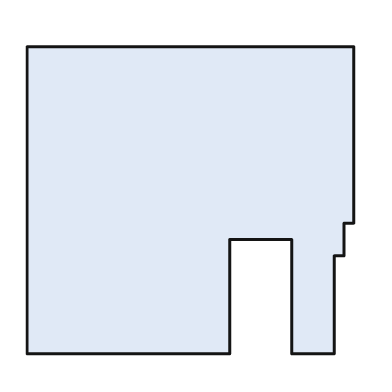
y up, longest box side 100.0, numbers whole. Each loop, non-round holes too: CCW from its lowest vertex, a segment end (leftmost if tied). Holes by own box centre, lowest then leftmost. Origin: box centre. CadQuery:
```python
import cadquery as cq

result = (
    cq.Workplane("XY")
    .moveTo(-50.0, -47.0)
    .lineTo(12.0, -47.0)
    .lineTo(12.0, -12.0)
    .lineTo(31.0, -12.0)
    .lineTo(31.0, -47.0)
    .lineTo(44.0, -47.0)
    .lineTo(44.0, -17.0)
    .lineTo(47.0, -17.0)
    .lineTo(47.0, -7.0)
    .lineTo(50.0, -7.0)
    .lineTo(50.0, 47.0)
    .lineTo(-50.0, 47.0)
    .close()
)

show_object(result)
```